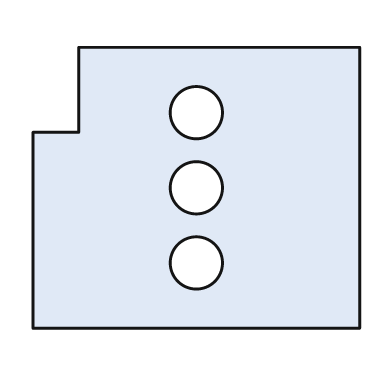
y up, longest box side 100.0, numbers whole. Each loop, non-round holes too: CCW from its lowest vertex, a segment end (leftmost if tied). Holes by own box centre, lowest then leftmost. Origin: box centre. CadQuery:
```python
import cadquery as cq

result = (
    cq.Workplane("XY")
    .moveTo(-50.0, -43.0)
    .lineTo(50.0, -43.0)
    .lineTo(50.0, 43.0)
    .lineTo(-36.0, 43.0)
    .lineTo(-36.0, 17.0)
    .lineTo(-50.0, 17.0)
    .close()
    .moveTo(0.0, -23.0)
    .circle(8.0)
    .moveTo(0.0, 0.0)
    .circle(8.0)
    .moveTo(0.0, 23.0)
    .circle(8.0)
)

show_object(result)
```